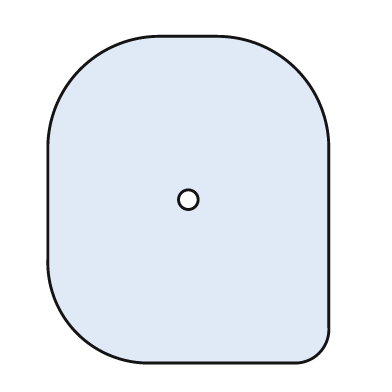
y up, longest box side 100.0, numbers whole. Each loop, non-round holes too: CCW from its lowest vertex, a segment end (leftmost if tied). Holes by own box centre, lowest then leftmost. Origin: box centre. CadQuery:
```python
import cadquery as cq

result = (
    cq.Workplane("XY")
    .moveTo(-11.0, -50.0)
    .lineTo(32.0, -50.0)
    .threePointArc((40.0, -47.0), (43.0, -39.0))
    .lineTo(43.0, 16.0)
    .threePointArc((33.0, 40.0), (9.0, 50.0))
    .lineTo(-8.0, 50.0)
    .threePointArc((-33.0, 40.0), (-43.0, 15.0))
    .lineTo(-43.0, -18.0)
    .threePointArc((-34.0, -41.0), (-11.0, -50.0))
    .close()
    .moveTo(0.0, 0.0)
    .circle(3.0)
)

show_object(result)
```